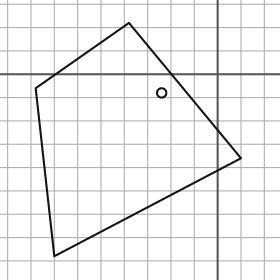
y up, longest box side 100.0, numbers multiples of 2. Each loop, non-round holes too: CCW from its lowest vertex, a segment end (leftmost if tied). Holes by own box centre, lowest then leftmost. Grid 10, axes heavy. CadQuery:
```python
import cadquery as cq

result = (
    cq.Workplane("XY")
    .moveTo(-70.0, -78.0)
    .lineTo(10.0, -36.0)
    .lineTo(-38.0, 22.0)
    .lineTo(-78.0, -6.0)
    .close()
    .moveTo(-24.0, -8.0)
    .circle(2.0)
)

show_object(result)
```